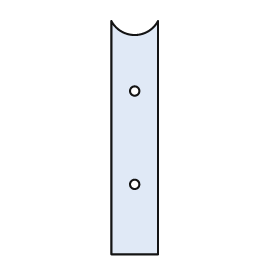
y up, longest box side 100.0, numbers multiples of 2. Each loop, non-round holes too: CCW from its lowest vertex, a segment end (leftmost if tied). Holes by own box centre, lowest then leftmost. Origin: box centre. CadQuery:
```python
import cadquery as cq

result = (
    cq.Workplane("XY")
    .moveTo(-10.0, -50.0)
    .lineTo(10.0, -50.0)
    .lineTo(10.0, 50.0)
    .threePointArc((0.0, 44.0), (-10.0, 50.0))
    .close()
    .moveTo(0.0, -20.0)
    .circle(2.0)
    .moveTo(0.0, 20.0)
    .circle(2.0)
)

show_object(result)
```